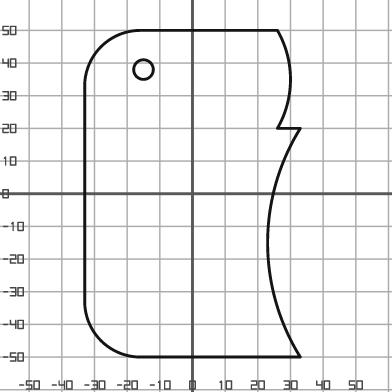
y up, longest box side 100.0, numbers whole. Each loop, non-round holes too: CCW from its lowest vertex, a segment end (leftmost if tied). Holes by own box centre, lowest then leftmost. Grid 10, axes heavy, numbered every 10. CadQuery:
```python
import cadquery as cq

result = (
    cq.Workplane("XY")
    .moveTo(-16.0, -50.0)
    .lineTo(33.0, -50.0)
    .threePointArc((23.0, -15.0), (33.0, 20.0))
    .lineTo(26.0, 20.0)
    .threePointArc((30.0, 35.0), (26.0, 50.0))
    .lineTo(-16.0, 50.0)
    .threePointArc((-28.0, 45.0), (-33.0, 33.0))
    .lineTo(-33.0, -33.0)
    .threePointArc((-28.0, -45.0), (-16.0, -50.0))
    .close()
    .moveTo(-15.0, 38.0)
    .circle(3.0)
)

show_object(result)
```